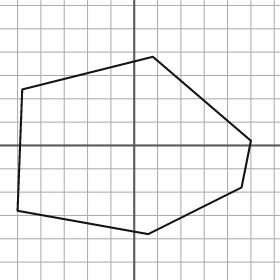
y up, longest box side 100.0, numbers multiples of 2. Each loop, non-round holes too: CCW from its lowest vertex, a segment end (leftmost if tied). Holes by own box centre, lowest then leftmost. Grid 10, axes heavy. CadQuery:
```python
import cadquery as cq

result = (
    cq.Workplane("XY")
    .moveTo(6.0, -38.0)
    .lineTo(46.0, -18.0)
    .lineTo(50.0, 2.0)
    .lineTo(8.0, 38.0)
    .lineTo(-48.0, 24.0)
    .lineTo(-50.0, -28.0)
    .close()
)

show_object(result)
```